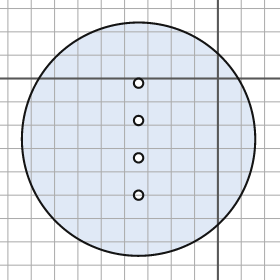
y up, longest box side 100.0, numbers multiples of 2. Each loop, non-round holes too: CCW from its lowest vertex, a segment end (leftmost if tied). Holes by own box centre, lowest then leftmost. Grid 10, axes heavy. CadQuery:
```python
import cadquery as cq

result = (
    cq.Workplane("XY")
    .moveTo(-34.0, -26.0)
    .circle(50.0)
    .moveTo(-34.0, -50.0)
    .circle(2.0)
    .moveTo(-34.0, -34.0)
    .circle(2.0)
    .moveTo(-34.0, -18.0)
    .circle(2.0)
    .moveTo(-34.0, -2.0)
    .circle(2.0)
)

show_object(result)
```